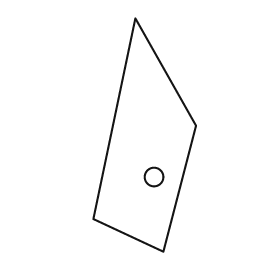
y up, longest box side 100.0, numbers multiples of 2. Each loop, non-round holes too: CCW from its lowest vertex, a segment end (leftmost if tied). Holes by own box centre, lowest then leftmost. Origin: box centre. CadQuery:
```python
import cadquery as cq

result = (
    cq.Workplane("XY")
    .moveTo(8.0, -50.0)
    .lineTo(22.0, 4.0)
    .lineTo(-4.0, 50.0)
    .lineTo(-22.0, -36.0)
    .close()
    .moveTo(4.0, -18.0)
    .circle(4.0)
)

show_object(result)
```